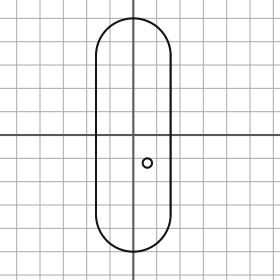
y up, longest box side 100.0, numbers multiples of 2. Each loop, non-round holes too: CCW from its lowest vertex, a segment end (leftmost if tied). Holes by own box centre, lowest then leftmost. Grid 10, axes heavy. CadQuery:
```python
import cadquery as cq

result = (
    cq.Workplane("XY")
    .moveTo(-16.0, -34.0)
    .threePointArc((0.0, -50.0), (16.0, -34.0))
    .lineTo(16.0, 34.0)
    .threePointArc((0.0, 50.0), (-16.0, 34.0))
    .close()
    .moveTo(6.0, -12.0)
    .circle(2.0)
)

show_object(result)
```